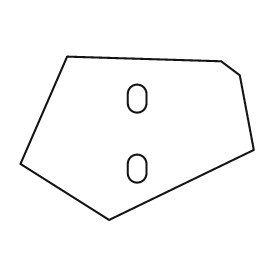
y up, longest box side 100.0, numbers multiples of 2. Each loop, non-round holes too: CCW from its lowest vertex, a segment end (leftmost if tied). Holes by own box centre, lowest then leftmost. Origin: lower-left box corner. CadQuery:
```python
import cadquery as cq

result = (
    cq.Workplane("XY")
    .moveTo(38.0, 0.0)
    .lineTo(100.0, 30.0)
    .lineTo(94.0, 62.0)
    .lineTo(86.0, 68.0)
    .lineTo(20.0, 70.0)
    .lineTo(0.0, 24.0)
    .close()
    .moveTo(46.0, 20.0)
    .threePointArc((50.0, 16.0), (54.0, 20.0))
    .lineTo(54.0, 24.0)
    .threePointArc((50.0, 28.0), (46.0, 24.0))
    .close()
    .moveTo(46.0, 50.0)
    .threePointArc((50.0, 46.0), (54.0, 50.0))
    .lineTo(54.0, 54.0)
    .threePointArc((50.0, 58.0), (46.0, 54.0))
    .close()
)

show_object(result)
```